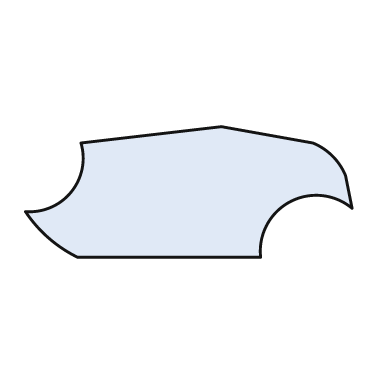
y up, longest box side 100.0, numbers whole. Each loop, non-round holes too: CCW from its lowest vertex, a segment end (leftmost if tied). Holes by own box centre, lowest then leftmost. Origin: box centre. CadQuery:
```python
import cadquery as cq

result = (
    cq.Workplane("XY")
    .moveTo(-34.0, -20.0)
    .lineTo(22.0, -20.0)
    .threePointArc((31.0, -3.0), (50.0, -5.0))
    .lineTo(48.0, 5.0)
    .threePointArc((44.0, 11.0), (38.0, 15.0))
    .lineTo(10.0, 20.0)
    .lineTo(-33.0, 15.0)
    .threePointArc((-36.0, 0.0), (-50.0, -6.0))
    .threePointArc((-43.0, -14.0), (-34.0, -20.0))
    .close()
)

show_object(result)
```